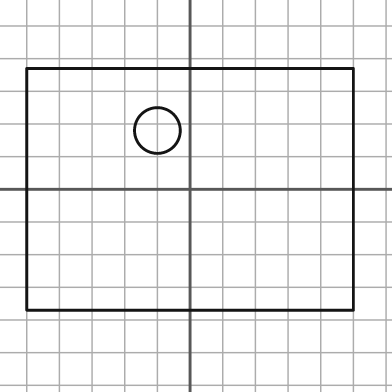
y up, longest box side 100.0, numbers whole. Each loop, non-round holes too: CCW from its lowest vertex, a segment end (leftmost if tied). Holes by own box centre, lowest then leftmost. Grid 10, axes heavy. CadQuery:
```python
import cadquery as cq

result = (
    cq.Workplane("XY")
    .moveTo(-50.0, -37.0)
    .lineTo(50.0, -37.0)
    .lineTo(50.0, 37.0)
    .lineTo(-50.0, 37.0)
    .close()
    .moveTo(-10.0, 18.0)
    .circle(7.0)
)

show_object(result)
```